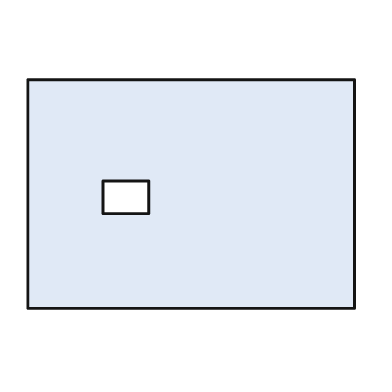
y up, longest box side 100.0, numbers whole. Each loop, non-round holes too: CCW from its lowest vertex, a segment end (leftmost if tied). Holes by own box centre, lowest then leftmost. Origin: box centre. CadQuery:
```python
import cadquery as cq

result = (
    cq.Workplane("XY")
    .moveTo(-50.0, -35.0)
    .lineTo(50.0, -35.0)
    .lineTo(50.0, 35.0)
    .lineTo(-50.0, 35.0)
    .close()
    .moveTo(-27.0, -6.0)
    .lineTo(-13.0, -6.0)
    .lineTo(-13.0, 4.0)
    .lineTo(-27.0, 4.0)
    .close()
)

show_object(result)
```